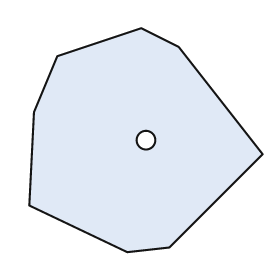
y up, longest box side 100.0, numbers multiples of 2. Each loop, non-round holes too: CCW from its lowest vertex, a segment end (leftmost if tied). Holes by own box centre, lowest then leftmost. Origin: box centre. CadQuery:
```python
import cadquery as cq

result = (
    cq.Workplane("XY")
    .moveTo(-8.0, -48.0)
    .lineTo(10.0, -46.0)
    .lineTo(50.0, -6.0)
    .lineTo(14.0, 40.0)
    .lineTo(-2.0, 48.0)
    .lineTo(-38.0, 36.0)
    .lineTo(-48.0, 12.0)
    .lineTo(-50.0, -28.0)
    .close()
    .moveTo(0.0, 0.0)
    .circle(4.0)
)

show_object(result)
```